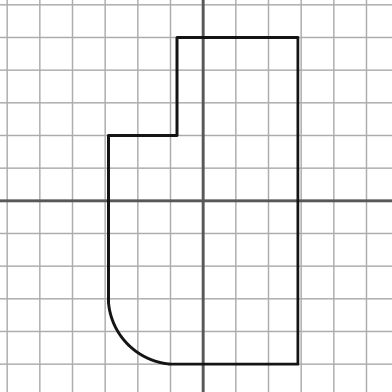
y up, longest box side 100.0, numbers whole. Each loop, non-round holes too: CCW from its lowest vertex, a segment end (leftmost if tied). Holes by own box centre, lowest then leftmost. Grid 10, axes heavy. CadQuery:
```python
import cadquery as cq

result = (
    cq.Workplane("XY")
    .moveTo(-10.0, -50.0)
    .lineTo(29.0, -50.0)
    .lineTo(29.0, 50.0)
    .lineTo(-8.0, 50.0)
    .lineTo(-8.0, 20.0)
    .lineTo(-29.0, 20.0)
    .lineTo(-29.0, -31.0)
    .threePointArc((-23.0, -44.0), (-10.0, -50.0))
    .close()
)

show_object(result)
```